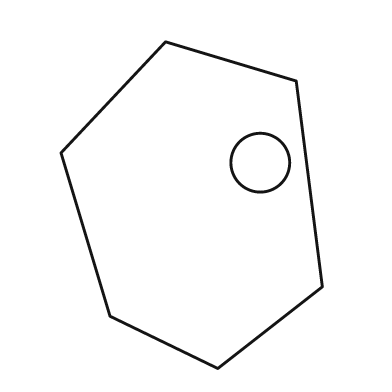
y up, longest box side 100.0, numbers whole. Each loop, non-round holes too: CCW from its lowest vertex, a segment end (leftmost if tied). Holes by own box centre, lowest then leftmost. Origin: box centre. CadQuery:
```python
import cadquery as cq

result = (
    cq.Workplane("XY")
    .moveTo(8.0, -50.0)
    .lineTo(40.0, -25.0)
    .lineTo(32.0, 38.0)
    .lineTo(-8.0, 50.0)
    .lineTo(-40.0, 16.0)
    .lineTo(-25.0, -34.0)
    .close()
    .moveTo(21.0, 13.0)
    .circle(9.0)
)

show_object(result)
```